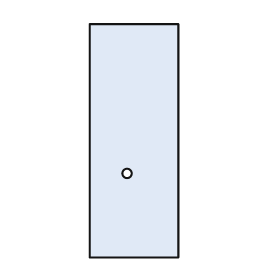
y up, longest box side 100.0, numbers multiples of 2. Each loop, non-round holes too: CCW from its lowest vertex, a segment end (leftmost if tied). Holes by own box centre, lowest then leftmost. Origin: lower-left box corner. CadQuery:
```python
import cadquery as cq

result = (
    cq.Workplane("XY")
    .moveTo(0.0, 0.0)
    .lineTo(38.0, 0.0)
    .lineTo(38.0, 100.0)
    .lineTo(0.0, 100.0)
    .close()
    .moveTo(16.0, 36.0)
    .circle(2.0)
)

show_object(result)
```